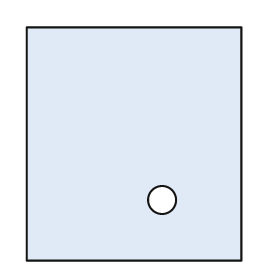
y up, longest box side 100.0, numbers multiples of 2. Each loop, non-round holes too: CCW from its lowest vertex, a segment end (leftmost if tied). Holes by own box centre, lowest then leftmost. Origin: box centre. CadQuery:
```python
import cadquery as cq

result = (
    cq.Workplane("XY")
    .moveTo(-46.0, -50.0)
    .lineTo(46.0, -50.0)
    .lineTo(46.0, 50.0)
    .lineTo(-46.0, 50.0)
    .close()
    .moveTo(12.0, -24.0)
    .circle(6.0)
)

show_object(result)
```